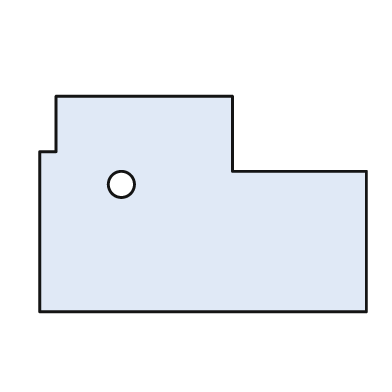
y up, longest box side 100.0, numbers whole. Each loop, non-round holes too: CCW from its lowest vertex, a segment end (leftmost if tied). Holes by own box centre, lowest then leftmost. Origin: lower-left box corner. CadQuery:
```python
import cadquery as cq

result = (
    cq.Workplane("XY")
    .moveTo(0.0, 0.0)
    .lineTo(100.0, 0.0)
    .lineTo(100.0, 43.0)
    .lineTo(59.0, 43.0)
    .lineTo(59.0, 66.0)
    .lineTo(5.0, 66.0)
    .lineTo(5.0, 49.0)
    .lineTo(0.0, 49.0)
    .close()
    .moveTo(25.0, 39.0)
    .circle(4.0)
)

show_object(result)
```